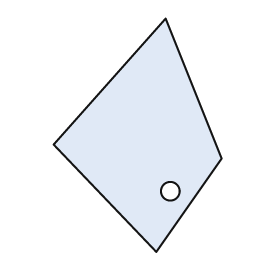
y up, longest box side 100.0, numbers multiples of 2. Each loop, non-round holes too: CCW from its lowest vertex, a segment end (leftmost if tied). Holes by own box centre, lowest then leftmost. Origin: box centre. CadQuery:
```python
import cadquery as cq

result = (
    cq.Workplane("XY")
    .moveTo(8.0, -50.0)
    .lineTo(36.0, -10.0)
    .lineTo(12.0, 50.0)
    .lineTo(-36.0, -4.0)
    .close()
    .moveTo(14.0, -24.0)
    .circle(4.0)
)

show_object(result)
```